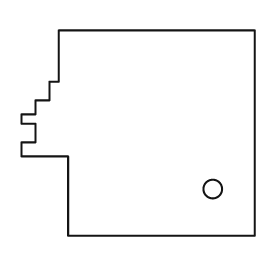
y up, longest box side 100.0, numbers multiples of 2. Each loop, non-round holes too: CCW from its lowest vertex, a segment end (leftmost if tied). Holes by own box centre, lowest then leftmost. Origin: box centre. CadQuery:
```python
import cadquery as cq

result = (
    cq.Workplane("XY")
    .moveTo(-30.0, -44.0)
    .lineTo(50.0, -44.0)
    .lineTo(50.0, 44.0)
    .lineTo(-34.0, 44.0)
    .lineTo(-34.0, 22.0)
    .lineTo(-38.0, 22.0)
    .lineTo(-38.0, 14.0)
    .lineTo(-44.0, 14.0)
    .lineTo(-44.0, 8.0)
    .lineTo(-50.0, 8.0)
    .lineTo(-50.0, 4.0)
    .lineTo(-44.0, 4.0)
    .lineTo(-44.0, -4.0)
    .lineTo(-50.0, -4.0)
    .lineTo(-50.0, -10.0)
    .lineTo(-30.0, -10.0)
    .close()
    .moveTo(32.0, -24.0)
    .circle(4.0)
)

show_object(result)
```